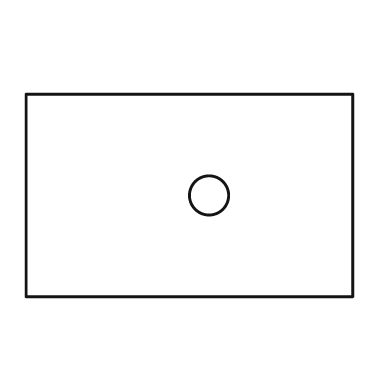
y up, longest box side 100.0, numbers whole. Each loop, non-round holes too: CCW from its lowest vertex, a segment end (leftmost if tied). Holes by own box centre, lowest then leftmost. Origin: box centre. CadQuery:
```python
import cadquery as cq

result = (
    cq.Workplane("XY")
    .moveTo(-50.0, -31.0)
    .lineTo(50.0, -31.0)
    .lineTo(50.0, 31.0)
    .lineTo(-50.0, 31.0)
    .close()
    .moveTo(6.0, 0.0)
    .circle(6.0)
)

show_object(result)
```